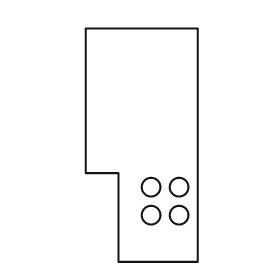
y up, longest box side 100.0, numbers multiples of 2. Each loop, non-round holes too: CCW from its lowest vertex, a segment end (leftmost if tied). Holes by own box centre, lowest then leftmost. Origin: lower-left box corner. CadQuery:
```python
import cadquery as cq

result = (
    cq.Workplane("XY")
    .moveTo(14.0, 0.0)
    .lineTo(48.0, 0.0)
    .lineTo(48.0, 100.0)
    .lineTo(0.0, 100.0)
    .lineTo(0.0, 38.0)
    .lineTo(14.0, 38.0)
    .close()
    .moveTo(28.0, 20.0)
    .circle(4.0)
    .moveTo(40.0, 20.0)
    .circle(4.0)
    .moveTo(28.0, 32.0)
    .circle(4.0)
    .moveTo(40.0, 32.0)
    .circle(4.0)
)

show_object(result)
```